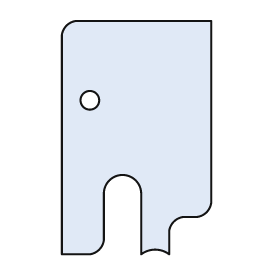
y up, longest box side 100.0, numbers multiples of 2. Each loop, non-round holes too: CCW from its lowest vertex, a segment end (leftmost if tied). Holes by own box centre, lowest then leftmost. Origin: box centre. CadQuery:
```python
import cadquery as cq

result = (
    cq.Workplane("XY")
    .moveTo(-32.0, -50.0)
    .lineTo(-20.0, -50.0)
    .threePointArc((-16.0, -48.0), (-14.0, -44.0))
    .lineTo(-14.0, -24.0)
    .threePointArc((-6.0, -16.0), (2.0, -24.0))
    .lineTo(2.0, -50.0)
    .threePointArc((8.0, -48.0), (14.0, -50.0))
    .lineTo(14.0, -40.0)
    .threePointArc((16.0, -36.0), (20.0, -34.0))
    .lineTo(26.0, -34.0)
    .threePointArc((30.0, -32.0), (32.0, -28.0))
    .lineTo(32.0, 50.0)
    .lineTo(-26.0, 50.0)
    .threePointArc((-30.0, 48.0), (-32.0, 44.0))
    .close()
    .moveTo(-20.0, 16.0)
    .circle(4.0)
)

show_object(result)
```